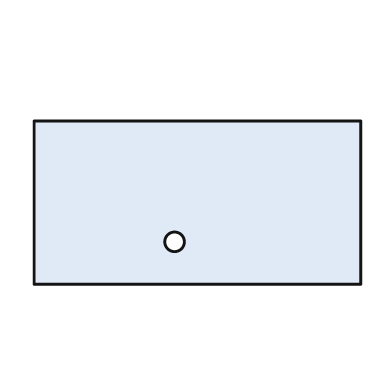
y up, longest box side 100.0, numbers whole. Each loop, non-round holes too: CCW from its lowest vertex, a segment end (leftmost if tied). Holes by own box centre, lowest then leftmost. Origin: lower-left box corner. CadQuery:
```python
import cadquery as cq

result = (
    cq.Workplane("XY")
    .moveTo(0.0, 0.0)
    .lineTo(100.0, 0.0)
    .lineTo(100.0, 50.0)
    .lineTo(0.0, 50.0)
    .close()
    .moveTo(43.0, 13.0)
    .circle(3.0)
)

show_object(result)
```